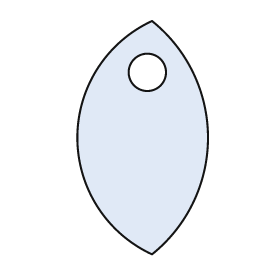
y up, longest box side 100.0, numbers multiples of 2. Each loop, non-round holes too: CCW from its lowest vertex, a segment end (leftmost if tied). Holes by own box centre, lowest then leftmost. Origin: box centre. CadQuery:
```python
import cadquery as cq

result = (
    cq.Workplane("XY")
    .moveTo(4.0, -50.0)
    .threePointArc((28.0, 0.0), (4.0, 50.0))
    .threePointArc((-28.0, 0.0), (4.0, -50.0))
    .close()
    .moveTo(2.0, 28.0)
    .circle(8.0)
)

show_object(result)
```